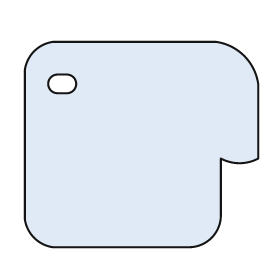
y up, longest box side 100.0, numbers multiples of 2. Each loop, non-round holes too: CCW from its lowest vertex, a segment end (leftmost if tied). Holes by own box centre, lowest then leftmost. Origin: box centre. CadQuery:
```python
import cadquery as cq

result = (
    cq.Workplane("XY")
    .moveTo(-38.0, -44.0)
    .lineTo(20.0, -44.0)
    .threePointArc((30.0, -40.0), (34.0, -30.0))
    .lineTo(34.0, -6.0)
    .threePointArc((42.0, -8.0), (50.0, -6.0))
    .lineTo(50.0, 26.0)
    .threePointArc((44.0, 38.0), (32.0, 44.0))
    .lineTo(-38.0, 44.0)
    .threePointArc((-46.0, 40.0), (-50.0, 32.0))
    .lineTo(-50.0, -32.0)
    .threePointArc((-46.0, -40.0), (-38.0, -44.0))
    .close()
    .moveTo(-36.0, 22.0)
    .lineTo(-32.0, 22.0)
    .threePointArc((-28.0, 26.0), (-32.0, 30.0))
    .lineTo(-36.0, 30.0)
    .threePointArc((-40.0, 26.0), (-36.0, 22.0))
    .close()
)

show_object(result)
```